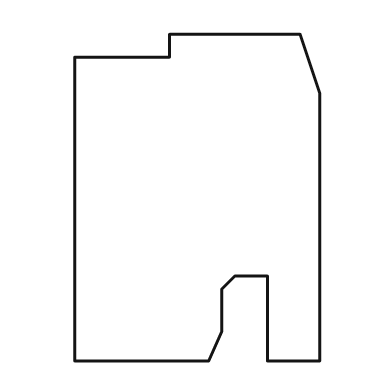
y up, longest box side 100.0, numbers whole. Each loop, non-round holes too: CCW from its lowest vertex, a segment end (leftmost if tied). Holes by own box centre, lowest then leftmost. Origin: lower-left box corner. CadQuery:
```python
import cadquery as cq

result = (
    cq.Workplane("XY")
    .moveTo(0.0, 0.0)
    .lineTo(41.0, 0.0)
    .lineTo(45.0, 9.0)
    .lineTo(45.0, 22.0)
    .lineTo(49.0, 26.0)
    .lineTo(59.0, 26.0)
    .lineTo(59.0, 0.0)
    .lineTo(75.0, 0.0)
    .lineTo(75.0, 82.0)
    .lineTo(69.0, 100.0)
    .lineTo(29.0, 100.0)
    .lineTo(29.0, 93.0)
    .lineTo(0.0, 93.0)
    .close()
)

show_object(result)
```